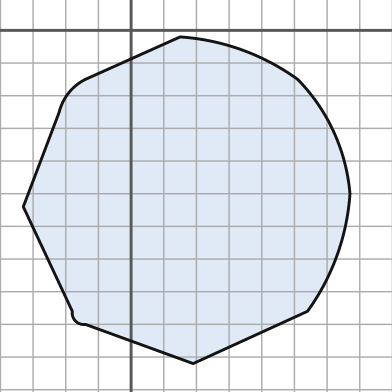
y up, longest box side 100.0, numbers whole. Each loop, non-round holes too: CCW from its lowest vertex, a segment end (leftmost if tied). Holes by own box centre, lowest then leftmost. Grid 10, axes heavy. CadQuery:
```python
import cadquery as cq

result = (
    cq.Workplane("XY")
    .moveTo(19.0, -102.0)
    .lineTo(54.0, -86.0)
    .threePointArc((63.0, -69.0), (67.0, -50.0))
    .threePointArc((62.0, -31.0), (51.0, -15.0))
    .threePointArc((34.0, -6.0), (15.0, -2.0))
    .lineTo(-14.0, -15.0)
    .threePointArc((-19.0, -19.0), (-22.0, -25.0))
    .lineTo(-33.0, -54.0)
    .lineTo(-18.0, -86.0)
    .threePointArc((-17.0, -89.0), (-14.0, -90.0))
    .close()
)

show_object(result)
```